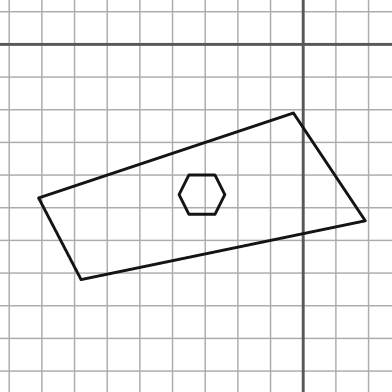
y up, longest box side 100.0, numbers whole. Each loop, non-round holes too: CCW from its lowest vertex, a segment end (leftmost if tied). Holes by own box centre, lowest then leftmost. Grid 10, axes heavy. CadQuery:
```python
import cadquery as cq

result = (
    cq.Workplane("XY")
    .moveTo(-68.0, -72.0)
    .lineTo(19.0, -54.0)
    .lineTo(-3.0, -21.0)
    .lineTo(-81.0, -47.0)
    .close()
    .moveTo(-35.0, -52.0)
    .lineTo(-27.0, -52.0)
    .lineTo(-24.0, -46.0)
    .lineTo(-27.0, -40.0)
    .lineTo(-35.0, -40.0)
    .lineTo(-38.0, -46.0)
    .close()
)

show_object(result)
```